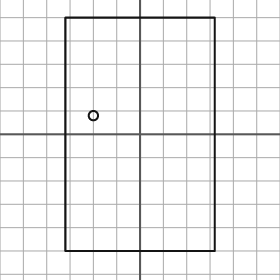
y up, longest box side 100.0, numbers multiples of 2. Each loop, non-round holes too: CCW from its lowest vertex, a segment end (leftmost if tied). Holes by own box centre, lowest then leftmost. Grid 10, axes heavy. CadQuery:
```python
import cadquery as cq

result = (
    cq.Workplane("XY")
    .moveTo(-32.0, -50.0)
    .lineTo(32.0, -50.0)
    .lineTo(32.0, 50.0)
    .lineTo(-32.0, 50.0)
    .close()
    .moveTo(-20.0, 8.0)
    .circle(2.0)
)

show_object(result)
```